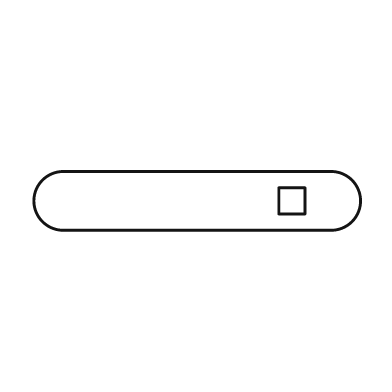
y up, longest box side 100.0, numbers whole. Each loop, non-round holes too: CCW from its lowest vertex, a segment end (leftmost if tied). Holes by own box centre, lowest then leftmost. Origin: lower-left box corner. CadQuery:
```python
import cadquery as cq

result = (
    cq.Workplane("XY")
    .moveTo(9.0, 0.0)
    .lineTo(91.0, 0.0)
    .threePointArc((100.0, 9.0), (91.0, 18.0))
    .lineTo(9.0, 18.0)
    .threePointArc((0.0, 9.0), (9.0, 0.0))
    .close()
    .moveTo(75.0, 5.0)
    .lineTo(83.0, 5.0)
    .lineTo(83.0, 13.0)
    .lineTo(75.0, 13.0)
    .close()
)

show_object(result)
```